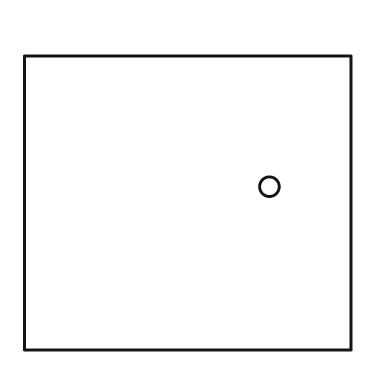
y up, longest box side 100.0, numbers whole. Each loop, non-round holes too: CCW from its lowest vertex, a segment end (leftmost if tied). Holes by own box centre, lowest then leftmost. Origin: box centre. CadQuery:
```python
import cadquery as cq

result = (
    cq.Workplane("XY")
    .moveTo(-50.0, -45.0)
    .lineTo(50.0, -45.0)
    .lineTo(50.0, 45.0)
    .lineTo(-50.0, 45.0)
    .close()
    .moveTo(25.0, 5.0)
    .circle(3.0)
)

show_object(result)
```